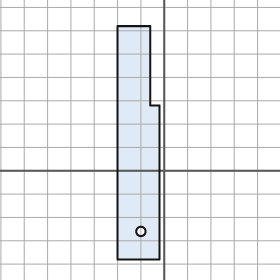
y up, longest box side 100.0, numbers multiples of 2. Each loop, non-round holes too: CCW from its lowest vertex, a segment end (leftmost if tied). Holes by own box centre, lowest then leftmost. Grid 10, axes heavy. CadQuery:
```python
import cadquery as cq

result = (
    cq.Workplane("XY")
    .moveTo(-20.0, -38.0)
    .lineTo(-2.0, -38.0)
    .lineTo(-2.0, 28.0)
    .lineTo(-6.0, 28.0)
    .lineTo(-6.0, 62.0)
    .lineTo(-20.0, 62.0)
    .close()
    .moveTo(-10.0, -26.0)
    .circle(2.0)
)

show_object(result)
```